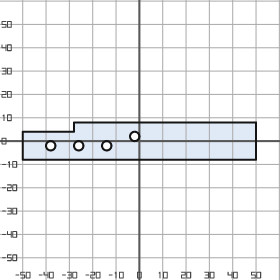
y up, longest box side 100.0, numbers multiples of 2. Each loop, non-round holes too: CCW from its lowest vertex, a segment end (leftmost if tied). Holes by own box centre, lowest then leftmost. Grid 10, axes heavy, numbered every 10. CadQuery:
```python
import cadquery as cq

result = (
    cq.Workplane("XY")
    .moveTo(-50.0, -8.0)
    .lineTo(50.0, -8.0)
    .lineTo(50.0, 8.0)
    .lineTo(-28.0, 8.0)
    .lineTo(-28.0, 4.0)
    .lineTo(-50.0, 4.0)
    .close()
    .moveTo(-38.0, -2.0)
    .circle(2.0)
    .moveTo(-26.0, -2.0)
    .circle(2.0)
    .moveTo(-14.0, -2.0)
    .circle(2.0)
    .moveTo(-2.0, 2.0)
    .circle(2.0)
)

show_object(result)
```